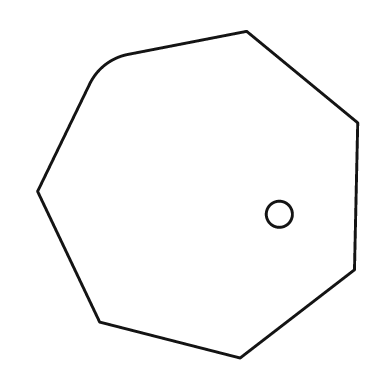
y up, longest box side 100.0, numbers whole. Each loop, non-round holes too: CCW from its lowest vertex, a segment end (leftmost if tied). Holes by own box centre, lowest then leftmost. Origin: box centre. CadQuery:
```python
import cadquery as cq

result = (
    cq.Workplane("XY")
    .moveTo(13.0, -50.0)
    .lineTo(48.0, -23.0)
    .lineTo(49.0, 22.0)
    .lineTo(15.0, 50.0)
    .lineTo(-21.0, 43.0)
    .threePointArc((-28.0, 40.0), (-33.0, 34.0))
    .lineTo(-49.0, 1.0)
    .lineTo(-30.0, -39.0)
    .close()
    .moveTo(25.0, -6.0)
    .circle(4.0)
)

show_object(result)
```